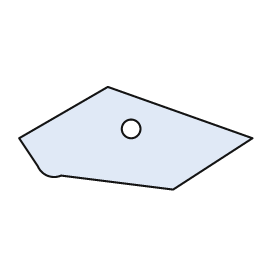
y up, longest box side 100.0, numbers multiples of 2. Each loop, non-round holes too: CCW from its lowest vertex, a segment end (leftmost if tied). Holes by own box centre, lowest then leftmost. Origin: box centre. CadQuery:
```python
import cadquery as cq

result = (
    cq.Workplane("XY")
    .moveTo(16.0, -22.0)
    .lineTo(50.0, 0.0)
    .lineTo(-12.0, 22.0)
    .lineTo(-50.0, 0.0)
    .lineTo(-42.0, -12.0)
    .threePointArc((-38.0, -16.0), (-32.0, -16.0))
    .close()
    .moveTo(-2.0, 4.0)
    .circle(4.0)
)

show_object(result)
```